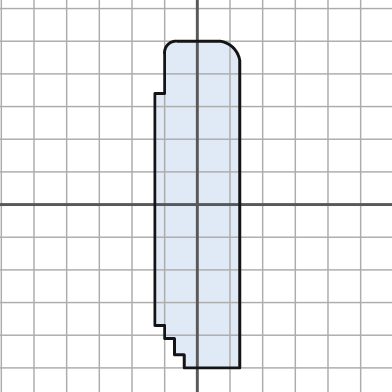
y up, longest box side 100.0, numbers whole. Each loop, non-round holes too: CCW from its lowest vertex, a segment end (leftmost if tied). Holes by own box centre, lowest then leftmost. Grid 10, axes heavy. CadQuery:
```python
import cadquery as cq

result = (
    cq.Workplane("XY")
    .moveTo(-4.0, -50.0)
    .lineTo(13.0, -50.0)
    .lineTo(13.0, 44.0)
    .threePointArc((11.0, 48.0), (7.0, 50.0))
    .lineTo(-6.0, 50.0)
    .threePointArc((-9.0, 49.0), (-10.0, 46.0))
    .lineTo(-10.0, 34.0)
    .lineTo(-13.0, 34.0)
    .lineTo(-13.0, -37.0)
    .lineTo(-10.0, -37.0)
    .lineTo(-10.0, -41.0)
    .lineTo(-7.0, -41.0)
    .lineTo(-7.0, -46.0)
    .lineTo(-4.0, -46.0)
    .close()
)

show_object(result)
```